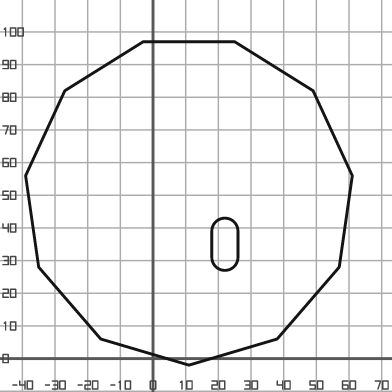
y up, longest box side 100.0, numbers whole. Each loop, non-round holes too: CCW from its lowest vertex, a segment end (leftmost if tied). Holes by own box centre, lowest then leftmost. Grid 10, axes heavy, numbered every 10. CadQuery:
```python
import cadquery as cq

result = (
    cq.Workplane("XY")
    .moveTo(11.0, -2.0)
    .lineTo(38.0, 6.0)
    .lineTo(57.0, 28.0)
    .lineTo(61.0, 56.0)
    .lineTo(49.0, 82.0)
    .lineTo(25.0, 97.0)
    .lineTo(-3.0, 97.0)
    .lineTo(-27.0, 82.0)
    .lineTo(-39.0, 56.0)
    .lineTo(-35.0, 28.0)
    .lineTo(-16.0, 6.0)
    .close()
    .moveTo(18.0, 31.0)
    .threePointArc((22.0, 27.0), (26.0, 31.0))
    .lineTo(26.0, 39.0)
    .threePointArc((22.0, 43.0), (18.0, 39.0))
    .close()
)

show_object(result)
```